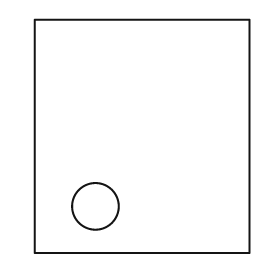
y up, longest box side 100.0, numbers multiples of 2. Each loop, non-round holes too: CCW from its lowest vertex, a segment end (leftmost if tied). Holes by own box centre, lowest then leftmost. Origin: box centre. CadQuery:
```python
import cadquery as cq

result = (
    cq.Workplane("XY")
    .moveTo(-46.0, -50.0)
    .lineTo(46.0, -50.0)
    .lineTo(46.0, 50.0)
    .lineTo(-46.0, 50.0)
    .close()
    .moveTo(-20.0, -30.0)
    .circle(10.0)
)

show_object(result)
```